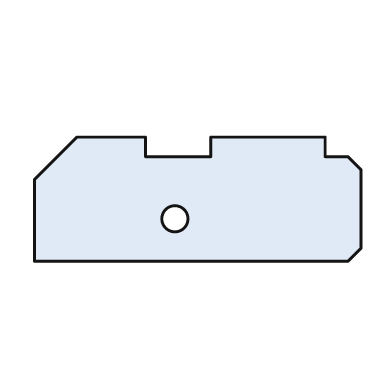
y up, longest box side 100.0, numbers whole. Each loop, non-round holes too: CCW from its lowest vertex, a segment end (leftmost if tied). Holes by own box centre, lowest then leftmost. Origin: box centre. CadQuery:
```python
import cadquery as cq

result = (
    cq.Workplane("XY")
    .moveTo(-50.0, -19.0)
    .lineTo(46.0, -19.0)
    .lineTo(50.0, -15.0)
    .lineTo(50.0, 9.0)
    .lineTo(46.0, 13.0)
    .lineTo(39.0, 13.0)
    .lineTo(39.0, 19.0)
    .lineTo(4.0, 19.0)
    .lineTo(4.0, 13.0)
    .lineTo(-16.0, 13.0)
    .lineTo(-16.0, 19.0)
    .lineTo(-37.0, 19.0)
    .lineTo(-50.0, 6.0)
    .close()
    .moveTo(-7.0, -6.0)
    .circle(4.0)
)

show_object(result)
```